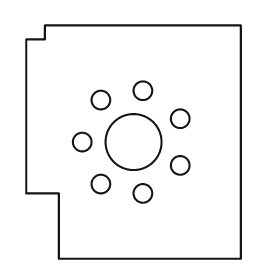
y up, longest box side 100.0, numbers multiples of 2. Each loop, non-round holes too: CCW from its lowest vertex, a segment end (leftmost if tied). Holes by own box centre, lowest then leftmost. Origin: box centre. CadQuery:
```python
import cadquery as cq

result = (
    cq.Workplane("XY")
    .moveTo(-32.0, -50.0)
    .lineTo(46.0, -50.0)
    .lineTo(46.0, 50.0)
    .lineTo(-38.0, 50.0)
    .lineTo(-38.0, 44.0)
    .lineTo(-46.0, 44.0)
    .lineTo(-46.0, -22.0)
    .lineTo(-32.0, -22.0)
    .close()
    .moveTo(4.0, -22.0)
    .circle(4.0)
    .moveTo(-14.0, -18.0)
    .circle(4.0)
    .moveTo(20.0, -10.0)
    .circle(4.0)
    .moveTo(-22.0, 0.0)
    .circle(4.0)
    .moveTo(0.0, 0.0)
    .circle(12.0)
    .moveTo(20.0, 10.0)
    .circle(4.0)
    .moveTo(-14.0, 18.0)
    .circle(4.0)
    .moveTo(4.0, 22.0)
    .circle(4.0)
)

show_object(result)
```